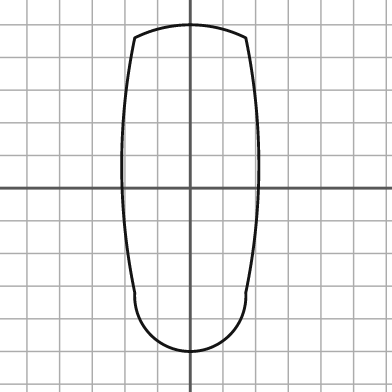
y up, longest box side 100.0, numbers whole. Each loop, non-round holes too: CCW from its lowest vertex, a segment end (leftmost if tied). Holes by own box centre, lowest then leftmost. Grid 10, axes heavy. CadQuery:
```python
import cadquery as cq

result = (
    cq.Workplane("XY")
    .moveTo(-17.0, -32.0)
    .threePointArc((0.0, -50.0), (17.0, -32.0))
    .threePointArc((21.0, 7.0), (17.0, 46.0))
    .threePointArc((0.0, 50.0), (-17.0, 46.0))
    .threePointArc((-21.0, 7.0), (-17.0, -32.0))
    .close()
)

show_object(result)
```